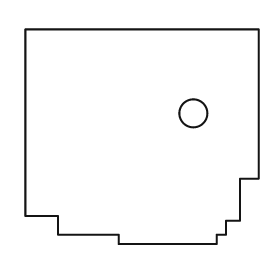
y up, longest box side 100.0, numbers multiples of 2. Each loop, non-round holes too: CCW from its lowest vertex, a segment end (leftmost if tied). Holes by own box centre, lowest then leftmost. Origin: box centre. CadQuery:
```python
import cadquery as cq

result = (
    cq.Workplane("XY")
    .moveTo(-10.0, -46.0)
    .lineTo(32.0, -46.0)
    .lineTo(32.0, -42.0)
    .lineTo(36.0, -42.0)
    .lineTo(36.0, -36.0)
    .lineTo(42.0, -36.0)
    .lineTo(42.0, -18.0)
    .lineTo(50.0, -18.0)
    .lineTo(50.0, 46.0)
    .lineTo(-50.0, 46.0)
    .lineTo(-50.0, -34.0)
    .lineTo(-36.0, -34.0)
    .lineTo(-36.0, -42.0)
    .lineTo(-10.0, -42.0)
    .close()
    .moveTo(22.0, 10.0)
    .circle(6.0)
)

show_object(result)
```